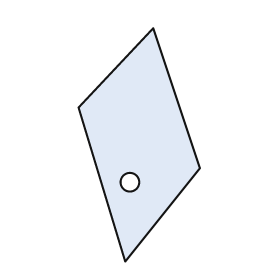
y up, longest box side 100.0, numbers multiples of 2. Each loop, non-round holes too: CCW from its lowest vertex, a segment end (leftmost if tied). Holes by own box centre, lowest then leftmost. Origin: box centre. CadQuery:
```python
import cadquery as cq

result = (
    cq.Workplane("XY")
    .moveTo(-6.0, -50.0)
    .lineTo(26.0, -10.0)
    .lineTo(6.0, 50.0)
    .lineTo(-26.0, 16.0)
    .close()
    .moveTo(-4.0, -16.0)
    .circle(4.0)
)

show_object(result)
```